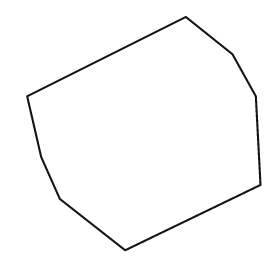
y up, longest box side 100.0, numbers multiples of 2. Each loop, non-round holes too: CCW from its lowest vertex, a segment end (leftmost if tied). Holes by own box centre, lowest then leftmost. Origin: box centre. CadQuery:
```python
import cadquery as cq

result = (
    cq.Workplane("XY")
    .moveTo(-8.0, -50.0)
    .lineTo(50.0, -22.0)
    .lineTo(48.0, 16.0)
    .lineTo(38.0, 34.0)
    .lineTo(18.0, 50.0)
    .lineTo(-50.0, 16.0)
    .lineTo(-44.0, -10.0)
    .lineTo(-36.0, -28.0)
    .close()
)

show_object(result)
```